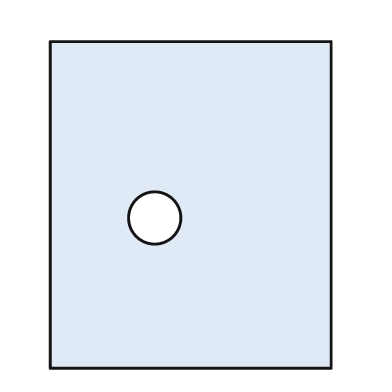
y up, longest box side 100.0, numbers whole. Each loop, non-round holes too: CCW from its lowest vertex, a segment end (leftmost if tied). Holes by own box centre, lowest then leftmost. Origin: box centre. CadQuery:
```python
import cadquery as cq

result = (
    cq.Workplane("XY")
    .moveTo(-43.0, -50.0)
    .lineTo(43.0, -50.0)
    .lineTo(43.0, 50.0)
    .lineTo(-43.0, 50.0)
    .close()
    .moveTo(-11.0, -4.0)
    .circle(8.0)
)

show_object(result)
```